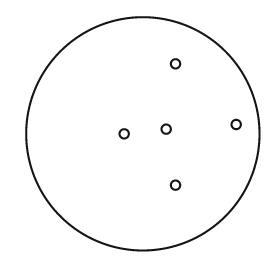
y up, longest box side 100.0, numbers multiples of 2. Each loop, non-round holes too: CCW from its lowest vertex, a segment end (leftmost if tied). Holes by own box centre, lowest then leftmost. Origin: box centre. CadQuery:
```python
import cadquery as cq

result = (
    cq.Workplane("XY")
    .moveTo(0.0, 0.0)
    .circle(50.0)
    .moveTo(14.0, -22.0)
    .circle(2.0)
    .moveTo(-8.0, 0.0)
    .circle(2.0)
    .moveTo(10.0, 2.0)
    .circle(2.0)
    .moveTo(40.0, 4.0)
    .circle(2.0)
    .moveTo(14.0, 30.0)
    .circle(2.0)
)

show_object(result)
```